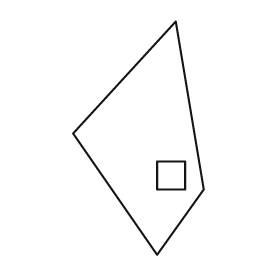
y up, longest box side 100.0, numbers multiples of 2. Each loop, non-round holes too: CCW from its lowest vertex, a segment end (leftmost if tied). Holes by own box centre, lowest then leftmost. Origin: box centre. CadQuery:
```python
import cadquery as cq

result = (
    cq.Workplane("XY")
    .moveTo(8.0, -50.0)
    .lineTo(28.0, -22.0)
    .lineTo(16.0, 50.0)
    .lineTo(-28.0, 2.0)
    .close()
    .moveTo(8.0, -22.0)
    .lineTo(20.0, -22.0)
    .lineTo(20.0, -10.0)
    .lineTo(8.0, -10.0)
    .close()
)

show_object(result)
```